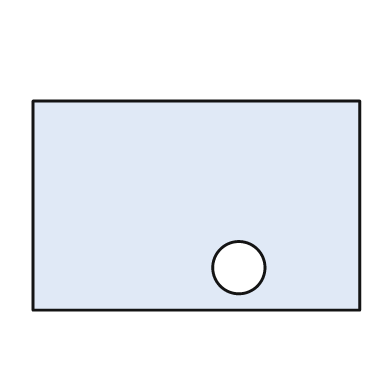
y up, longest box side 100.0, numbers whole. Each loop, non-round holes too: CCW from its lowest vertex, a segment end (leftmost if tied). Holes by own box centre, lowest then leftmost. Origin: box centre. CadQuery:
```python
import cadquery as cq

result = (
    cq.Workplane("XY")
    .moveTo(-50.0, -32.0)
    .lineTo(50.0, -32.0)
    .lineTo(50.0, 32.0)
    .lineTo(-50.0, 32.0)
    .close()
    .moveTo(13.0, -19.0)
    .circle(8.0)
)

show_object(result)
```